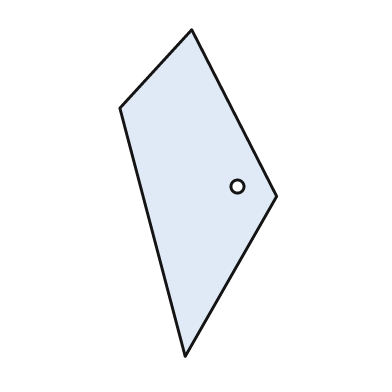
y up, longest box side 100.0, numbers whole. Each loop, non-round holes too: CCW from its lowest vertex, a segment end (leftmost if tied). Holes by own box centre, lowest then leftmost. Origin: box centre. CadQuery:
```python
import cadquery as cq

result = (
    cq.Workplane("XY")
    .moveTo(-4.0, -50.0)
    .lineTo(24.0, -1.0)
    .lineTo(-2.0, 50.0)
    .lineTo(-24.0, 26.0)
    .close()
    .moveTo(12.0, 2.0)
    .circle(2.0)
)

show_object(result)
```